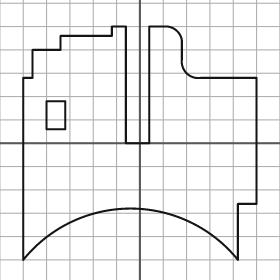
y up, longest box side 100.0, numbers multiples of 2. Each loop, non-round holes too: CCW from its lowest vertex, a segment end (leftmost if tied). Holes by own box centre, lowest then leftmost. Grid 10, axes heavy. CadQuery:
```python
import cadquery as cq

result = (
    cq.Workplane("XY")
    .moveTo(-50.0, -50.0)
    .threePointArc((-4.0, -28.0), (42.0, -50.0))
    .lineTo(42.0, -26.0)
    .lineTo(50.0, -26.0)
    .lineTo(50.0, 28.0)
    .lineTo(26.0, 28.0)
    .threePointArc((20.0, 30.0), (18.0, 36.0))
    .lineTo(18.0, 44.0)
    .threePointArc((16.0, 48.0), (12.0, 50.0))
    .lineTo(4.0, 50.0)
    .lineTo(4.0, 0.0)
    .lineTo(-6.0, 0.0)
    .lineTo(-6.0, 50.0)
    .lineTo(-12.0, 50.0)
    .lineTo(-12.0, 46.0)
    .lineTo(-34.0, 46.0)
    .lineTo(-34.0, 40.0)
    .lineTo(-46.0, 40.0)
    .lineTo(-46.0, 28.0)
    .lineTo(-50.0, 28.0)
    .close()
    .moveTo(-40.0, 6.0)
    .lineTo(-32.0, 6.0)
    .lineTo(-32.0, 18.0)
    .lineTo(-40.0, 18.0)
    .close()
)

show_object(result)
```